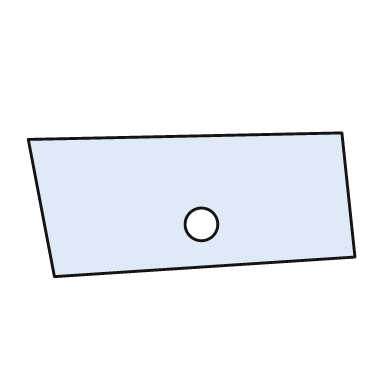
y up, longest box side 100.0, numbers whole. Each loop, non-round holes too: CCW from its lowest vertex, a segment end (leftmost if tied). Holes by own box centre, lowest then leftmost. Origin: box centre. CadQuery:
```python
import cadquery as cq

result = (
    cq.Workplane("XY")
    .moveTo(-42.0, -22.0)
    .lineTo(50.0, -16.0)
    .lineTo(46.0, 22.0)
    .lineTo(-50.0, 20.0)
    .close()
    .moveTo(3.0, -6.0)
    .circle(5.0)
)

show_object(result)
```